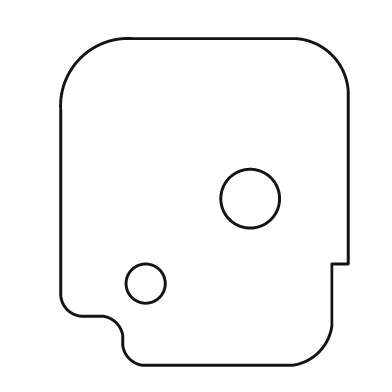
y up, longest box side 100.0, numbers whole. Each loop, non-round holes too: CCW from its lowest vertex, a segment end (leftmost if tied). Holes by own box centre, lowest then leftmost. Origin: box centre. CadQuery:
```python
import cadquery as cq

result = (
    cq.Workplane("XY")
    .moveTo(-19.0, -50.0)
    .lineTo(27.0, -50.0)
    .threePointArc((35.0, -46.0), (39.0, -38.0))
    .lineTo(39.0, -19.0)
    .lineTo(44.0, -19.0)
    .lineTo(44.0, 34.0)
    .threePointArc((39.0, 45.0), (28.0, 50.0))
    .lineTo(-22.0, 50.0)
    .threePointArc((-38.0, 44.0), (-44.0, 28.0))
    .lineTo(-44.0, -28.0)
    .threePointArc((-42.0, -33.0), (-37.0, -35.0))
    .lineTo(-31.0, -35.0)
    .threePointArc((-27.0, -37.0), (-25.0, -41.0))
    .lineTo(-25.0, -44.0)
    .threePointArc((-23.0, -48.0), (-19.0, -50.0))
    .close()
    .moveTo(-18.0, -25.0)
    .circle(6.0)
    .moveTo(14.0, 1.0)
    .circle(9.0)
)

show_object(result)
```